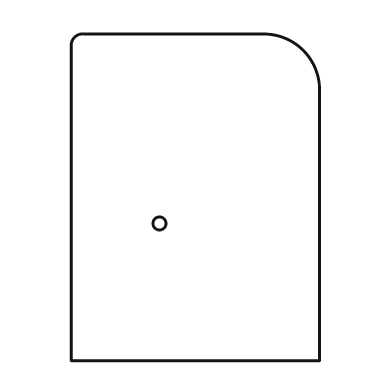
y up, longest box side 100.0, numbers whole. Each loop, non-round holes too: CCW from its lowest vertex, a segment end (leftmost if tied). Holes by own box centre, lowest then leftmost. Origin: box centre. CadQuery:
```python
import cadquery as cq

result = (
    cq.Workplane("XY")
    .moveTo(-38.0, -50.0)
    .lineTo(38.0, -50.0)
    .lineTo(38.0, 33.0)
    .threePointArc((33.0, 45.0), (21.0, 50.0))
    .lineTo(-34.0, 50.0)
    .threePointArc((-37.0, 49.0), (-38.0, 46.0))
    .close()
    .moveTo(-11.0, -8.0)
    .circle(2.0)
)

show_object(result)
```